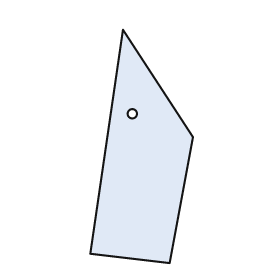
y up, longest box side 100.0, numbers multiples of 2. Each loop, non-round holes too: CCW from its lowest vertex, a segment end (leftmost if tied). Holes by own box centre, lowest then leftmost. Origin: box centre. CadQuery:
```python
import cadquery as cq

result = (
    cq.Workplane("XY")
    .moveTo(12.0, -50.0)
    .lineTo(22.0, 4.0)
    .lineTo(-8.0, 50.0)
    .lineTo(-22.0, -46.0)
    .close()
    .moveTo(-4.0, 14.0)
    .circle(2.0)
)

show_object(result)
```